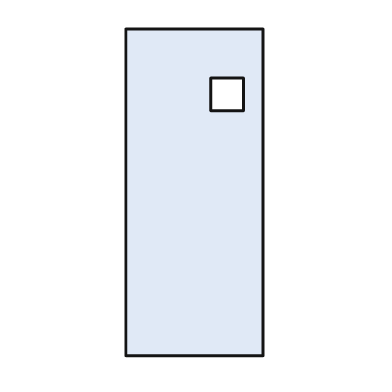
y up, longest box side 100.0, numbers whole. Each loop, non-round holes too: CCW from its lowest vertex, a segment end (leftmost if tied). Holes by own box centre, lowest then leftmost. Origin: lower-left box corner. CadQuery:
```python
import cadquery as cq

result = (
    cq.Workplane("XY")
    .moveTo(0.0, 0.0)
    .lineTo(42.0, 0.0)
    .lineTo(42.0, 100.0)
    .lineTo(0.0, 100.0)
    .close()
    .moveTo(26.0, 75.0)
    .lineTo(36.0, 75.0)
    .lineTo(36.0, 85.0)
    .lineTo(26.0, 85.0)
    .close()
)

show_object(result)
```